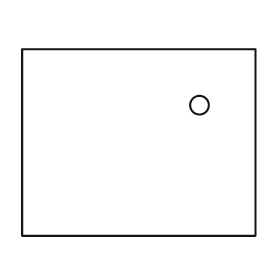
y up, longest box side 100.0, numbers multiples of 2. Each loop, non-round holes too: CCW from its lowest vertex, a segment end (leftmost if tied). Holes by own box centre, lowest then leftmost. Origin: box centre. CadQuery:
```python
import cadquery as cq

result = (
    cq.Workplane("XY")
    .moveTo(-50.0, -40.0)
    .lineTo(50.0, -40.0)
    .lineTo(50.0, 40.0)
    .lineTo(-50.0, 40.0)
    .close()
    .moveTo(26.0, 16.0)
    .circle(4.0)
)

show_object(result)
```